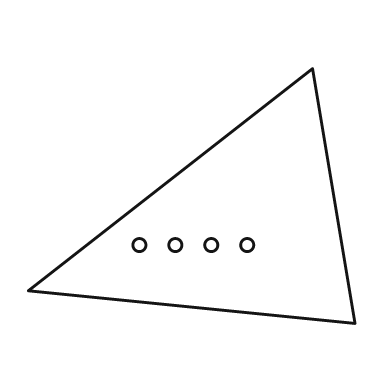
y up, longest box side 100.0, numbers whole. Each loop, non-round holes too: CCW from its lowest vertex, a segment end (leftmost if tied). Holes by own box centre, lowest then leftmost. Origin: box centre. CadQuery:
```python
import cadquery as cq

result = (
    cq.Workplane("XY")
    .moveTo(50.0, -39.0)
    .lineTo(37.0, 39.0)
    .lineTo(-50.0, -29.0)
    .close()
    .moveTo(-16.0, -15.0)
    .circle(2.0)
    .moveTo(-5.0, -15.0)
    .circle(2.0)
    .moveTo(6.0, -15.0)
    .circle(2.0)
    .moveTo(17.0, -15.0)
    .circle(2.0)
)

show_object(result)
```